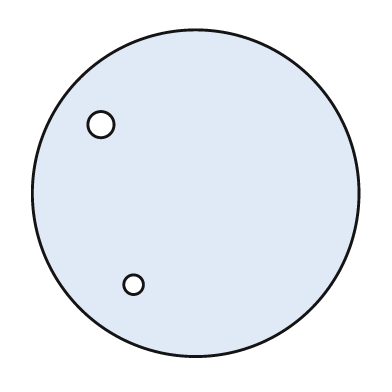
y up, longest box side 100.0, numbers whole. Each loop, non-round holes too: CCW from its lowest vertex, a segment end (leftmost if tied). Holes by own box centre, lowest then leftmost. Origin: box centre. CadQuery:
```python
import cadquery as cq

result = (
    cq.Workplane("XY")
    .moveTo(0.0, 0.0)
    .circle(50.0)
    .moveTo(-19.0, -28.0)
    .circle(3.0)
    .moveTo(-29.0, 21.0)
    .circle(4.0)
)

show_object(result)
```